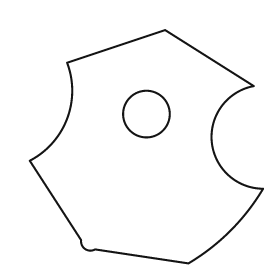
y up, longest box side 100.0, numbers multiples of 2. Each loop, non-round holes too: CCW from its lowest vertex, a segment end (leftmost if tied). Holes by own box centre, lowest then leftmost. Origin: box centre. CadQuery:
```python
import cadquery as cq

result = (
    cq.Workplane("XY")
    .moveTo(18.0, -50.0)
    .threePointArc((36.0, -36.0), (50.0, -18.0))
    .threePointArc((28.0, 2.0), (46.0, 26.0))
    .lineTo(8.0, 50.0)
    .lineTo(-34.0, 36.0)
    .threePointArc((-34.0, 12.0), (-50.0, -6.0))
    .lineTo(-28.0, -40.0)
    .threePointArc((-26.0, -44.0), (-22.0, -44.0))
    .close()
    .moveTo(0.0, 14.0)
    .circle(10.0)
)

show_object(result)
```